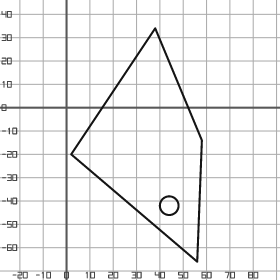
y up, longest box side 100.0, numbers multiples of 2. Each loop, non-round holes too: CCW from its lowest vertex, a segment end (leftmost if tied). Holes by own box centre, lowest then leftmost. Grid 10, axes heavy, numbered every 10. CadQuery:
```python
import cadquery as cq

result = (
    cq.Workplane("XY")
    .moveTo(56.0, -66.0)
    .lineTo(58.0, -14.0)
    .lineTo(38.0, 34.0)
    .lineTo(2.0, -20.0)
    .close()
    .moveTo(44.0, -42.0)
    .circle(4.0)
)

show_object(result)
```